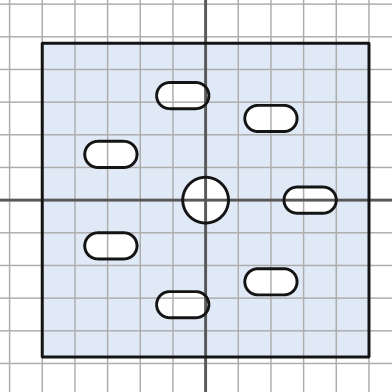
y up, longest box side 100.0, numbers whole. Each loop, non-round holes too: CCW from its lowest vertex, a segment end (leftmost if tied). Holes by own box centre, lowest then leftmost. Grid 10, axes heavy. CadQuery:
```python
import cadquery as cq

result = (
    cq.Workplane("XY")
    .moveTo(-50.0, -48.0)
    .lineTo(50.0, -48.0)
    .lineTo(50.0, 48.0)
    .lineTo(-50.0, 48.0)
    .close()
    .moveTo(-11.0, -36.0)
    .lineTo(-3.0, -36.0)
    .threePointArc((1.0, -32.0), (-3.0, -28.0))
    .lineTo(-11.0, -28.0)
    .threePointArc((-15.0, -32.0), (-11.0, -36.0))
    .close()
    .moveTo(16.0, -29.0)
    .lineTo(24.0, -29.0)
    .threePointArc((28.0, -25.0), (24.0, -21.0))
    .lineTo(16.0, -21.0)
    .threePointArc((12.0, -25.0), (16.0, -29.0))
    .close()
    .moveTo(-33.0, -18.0)
    .lineTo(-25.0, -18.0)
    .threePointArc((-21.0, -14.0), (-25.0, -10.0))
    .lineTo(-33.0, -10.0)
    .threePointArc((-37.0, -14.0), (-33.0, -18.0))
    .close()
    .moveTo(0.0, 0.0)
    .circle(7.0)
    .moveTo(28.0, -4.0)
    .lineTo(36.0, -4.0)
    .threePointArc((40.0, 0.0), (36.0, 4.0))
    .lineTo(28.0, 4.0)
    .threePointArc((24.0, 0.0), (28.0, -4.0))
    .close()
    .moveTo(-33.0, 10.0)
    .lineTo(-25.0, 10.0)
    .threePointArc((-21.0, 14.0), (-25.0, 18.0))
    .lineTo(-33.0, 18.0)
    .threePointArc((-37.0, 14.0), (-33.0, 10.0))
    .close()
    .moveTo(16.0, 21.0)
    .lineTo(24.0, 21.0)
    .threePointArc((28.0, 25.0), (24.0, 29.0))
    .lineTo(16.0, 29.0)
    .threePointArc((12.0, 25.0), (16.0, 21.0))
    .close()
    .moveTo(-11.0, 28.0)
    .lineTo(-3.0, 28.0)
    .threePointArc((1.0, 32.0), (-3.0, 36.0))
    .lineTo(-11.0, 36.0)
    .threePointArc((-15.0, 32.0), (-11.0, 28.0))
    .close()
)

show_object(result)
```